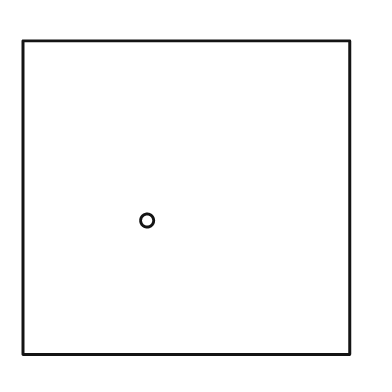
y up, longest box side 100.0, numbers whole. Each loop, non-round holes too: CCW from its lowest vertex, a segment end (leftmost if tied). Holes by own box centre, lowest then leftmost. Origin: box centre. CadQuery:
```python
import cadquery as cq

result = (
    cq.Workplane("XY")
    .moveTo(-50.0, -48.0)
    .lineTo(50.0, -48.0)
    .lineTo(50.0, 48.0)
    .lineTo(-50.0, 48.0)
    .close()
    .moveTo(-12.0, -7.0)
    .circle(2.0)
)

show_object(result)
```